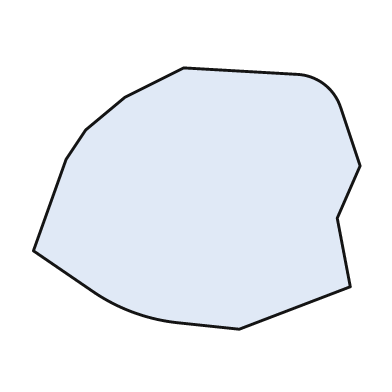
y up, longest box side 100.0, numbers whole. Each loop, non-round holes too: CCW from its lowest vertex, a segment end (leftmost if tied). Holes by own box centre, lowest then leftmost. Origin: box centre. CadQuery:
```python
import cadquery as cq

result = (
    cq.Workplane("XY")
    .moveTo(13.0, -40.0)
    .lineTo(47.0, -27.0)
    .lineTo(43.0, -6.0)
    .lineTo(50.0, 10.0)
    .lineTo(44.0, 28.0)
    .threePointArc((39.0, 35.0), (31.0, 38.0))
    .lineTo(-4.0, 40.0)
    .lineTo(-22.0, 31.0)
    .lineTo(-34.0, 21.0)
    .lineTo(-40.0, 12.0)
    .lineTo(-50.0, -16.0)
    .lineTo(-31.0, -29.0)
    .threePointArc((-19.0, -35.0), (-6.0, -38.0))
    .close()
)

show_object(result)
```